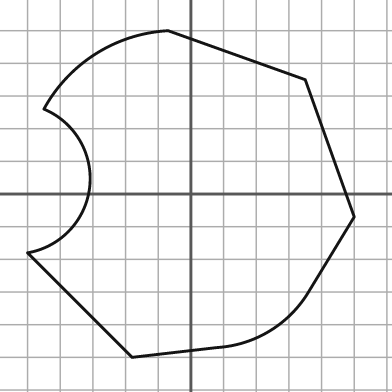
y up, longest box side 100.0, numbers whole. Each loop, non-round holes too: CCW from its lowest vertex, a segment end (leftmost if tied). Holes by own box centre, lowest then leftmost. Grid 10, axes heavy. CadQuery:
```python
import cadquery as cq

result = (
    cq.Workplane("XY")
    .moveTo(-18.0, -50.0)
    .lineTo(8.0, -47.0)
    .threePointArc((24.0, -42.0), (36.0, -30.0))
    .lineTo(50.0, -7.0)
    .lineTo(35.0, 35.0)
    .lineTo(-7.0, 50.0)
    .threePointArc((-29.0, 43.0), (-45.0, 26.0))
    .threePointArc((-31.0, 2.0), (-50.0, -18.0))
    .close()
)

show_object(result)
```